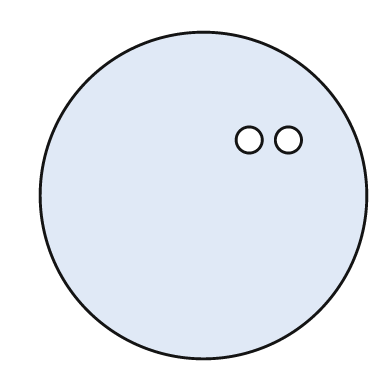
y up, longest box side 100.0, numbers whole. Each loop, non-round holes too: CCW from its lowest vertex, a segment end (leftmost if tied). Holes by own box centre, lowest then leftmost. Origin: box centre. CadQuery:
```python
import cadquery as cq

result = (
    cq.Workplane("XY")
    .moveTo(0.0, 0.0)
    .circle(50.0)
    .moveTo(14.0, 17.0)
    .circle(4.0)
    .moveTo(26.0, 17.0)
    .circle(4.0)
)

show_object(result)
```